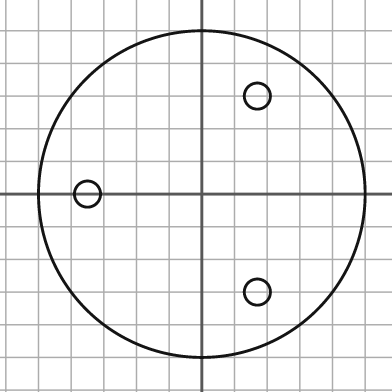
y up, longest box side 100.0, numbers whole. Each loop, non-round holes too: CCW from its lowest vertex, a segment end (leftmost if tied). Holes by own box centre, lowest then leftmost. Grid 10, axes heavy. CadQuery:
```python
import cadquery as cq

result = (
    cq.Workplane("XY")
    .moveTo(0.0, 0.0)
    .circle(50.0)
    .moveTo(17.0, -30.0)
    .circle(4.0)
    .moveTo(-35.0, 0.0)
    .circle(4.0)
    .moveTo(17.0, 30.0)
    .circle(4.0)
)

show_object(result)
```